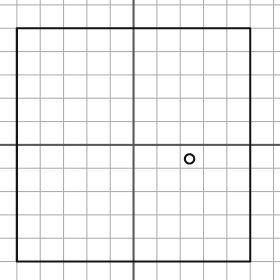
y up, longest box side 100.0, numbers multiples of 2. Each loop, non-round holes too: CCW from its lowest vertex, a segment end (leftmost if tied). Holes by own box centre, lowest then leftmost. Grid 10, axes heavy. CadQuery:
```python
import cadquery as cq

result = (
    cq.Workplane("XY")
    .moveTo(-50.0, -50.0)
    .lineTo(50.0, -50.0)
    .lineTo(50.0, 50.0)
    .lineTo(-50.0, 50.0)
    .close()
    .moveTo(24.0, -6.0)
    .circle(2.0)
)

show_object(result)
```